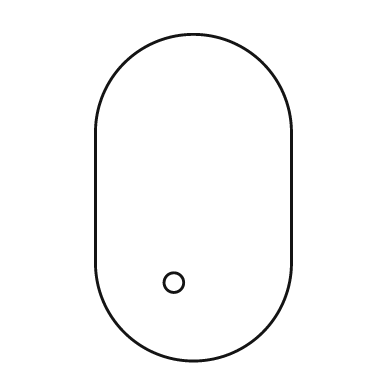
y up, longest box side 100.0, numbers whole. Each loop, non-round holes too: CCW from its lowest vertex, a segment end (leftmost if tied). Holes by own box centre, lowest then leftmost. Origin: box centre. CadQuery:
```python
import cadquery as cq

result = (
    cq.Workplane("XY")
    .moveTo(-30.0, -20.0)
    .threePointArc((0.0, -50.0), (30.0, -20.0))
    .lineTo(30.0, 20.0)
    .threePointArc((0.0, 50.0), (-30.0, 20.0))
    .close()
    .moveTo(-6.0, -26.0)
    .circle(3.0)
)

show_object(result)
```